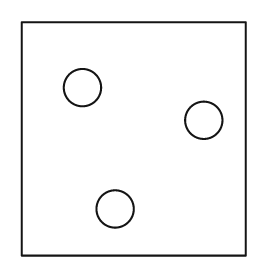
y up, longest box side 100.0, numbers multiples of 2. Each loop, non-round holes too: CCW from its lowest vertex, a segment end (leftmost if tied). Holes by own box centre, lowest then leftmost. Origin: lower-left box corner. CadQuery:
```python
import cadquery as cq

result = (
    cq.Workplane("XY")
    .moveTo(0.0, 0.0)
    .lineTo(96.0, 0.0)
    .lineTo(96.0, 100.0)
    .lineTo(0.0, 100.0)
    .close()
    .moveTo(40.0, 20.0)
    .circle(8.0)
    .moveTo(78.0, 58.0)
    .circle(8.0)
    .moveTo(26.0, 72.0)
    .circle(8.0)
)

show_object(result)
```